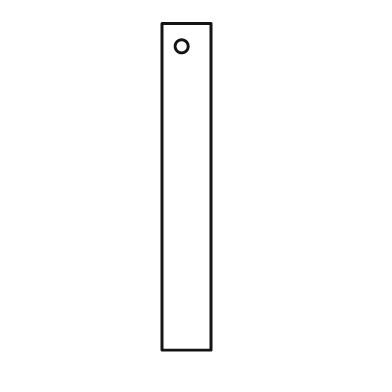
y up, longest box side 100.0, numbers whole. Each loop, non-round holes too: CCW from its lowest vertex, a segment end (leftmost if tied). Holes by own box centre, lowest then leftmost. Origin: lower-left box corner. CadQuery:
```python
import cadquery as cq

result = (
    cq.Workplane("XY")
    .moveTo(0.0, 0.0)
    .lineTo(15.0, 0.0)
    .lineTo(15.0, 100.0)
    .lineTo(0.0, 100.0)
    .close()
    .moveTo(6.0, 93.0)
    .circle(2.0)
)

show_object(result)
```